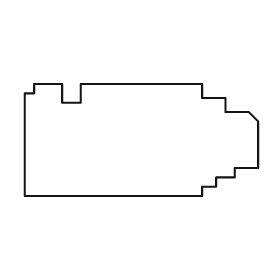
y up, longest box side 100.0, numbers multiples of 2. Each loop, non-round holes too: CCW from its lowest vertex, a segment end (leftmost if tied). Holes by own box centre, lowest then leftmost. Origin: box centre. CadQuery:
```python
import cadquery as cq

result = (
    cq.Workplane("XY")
    .moveTo(-50.0, -24.0)
    .lineTo(26.0, -24.0)
    .lineTo(26.0, -20.0)
    .lineTo(32.0, -20.0)
    .lineTo(32.0, -16.0)
    .lineTo(40.0, -16.0)
    .lineTo(40.0, -12.0)
    .lineTo(50.0, -12.0)
    .lineTo(50.0, 8.0)
    .lineTo(46.0, 12.0)
    .lineTo(36.0, 12.0)
    .lineTo(36.0, 18.0)
    .lineTo(26.0, 18.0)
    .lineTo(26.0, 24.0)
    .lineTo(-26.0, 24.0)
    .lineTo(-26.0, 16.0)
    .lineTo(-34.0, 16.0)
    .lineTo(-34.0, 24.0)
    .lineTo(-46.0, 24.0)
    .lineTo(-46.0, 20.0)
    .lineTo(-50.0, 20.0)
    .close()
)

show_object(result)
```